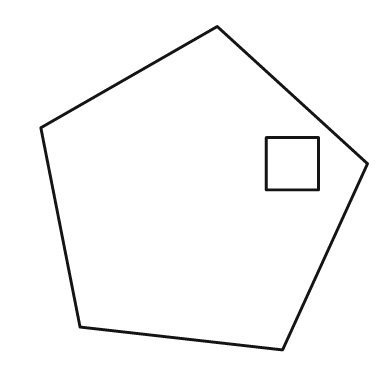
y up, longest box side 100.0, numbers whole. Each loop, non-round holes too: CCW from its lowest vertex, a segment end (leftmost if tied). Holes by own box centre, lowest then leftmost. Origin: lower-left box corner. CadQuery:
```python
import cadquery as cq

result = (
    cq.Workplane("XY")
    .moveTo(74.0, 0.0)
    .lineTo(100.0, 57.0)
    .lineTo(54.0, 99.0)
    .lineTo(0.0, 68.0)
    .lineTo(12.0, 7.0)
    .close()
    .moveTo(69.0, 49.0)
    .lineTo(85.0, 49.0)
    .lineTo(85.0, 65.0)
    .lineTo(69.0, 65.0)
    .close()
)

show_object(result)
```